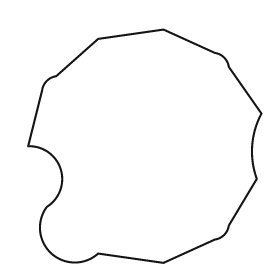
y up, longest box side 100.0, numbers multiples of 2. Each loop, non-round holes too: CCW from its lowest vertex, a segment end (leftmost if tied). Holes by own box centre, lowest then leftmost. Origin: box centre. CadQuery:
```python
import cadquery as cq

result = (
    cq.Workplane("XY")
    .moveTo(8.0, -50.0)
    .lineTo(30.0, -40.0)
    .threePointArc((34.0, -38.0), (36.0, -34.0))
    .lineTo(48.0, -14.0)
    .threePointArc((46.0, 0.0), (50.0, 14.0))
    .lineTo(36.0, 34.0)
    .threePointArc((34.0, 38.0), (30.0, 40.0))
    .lineTo(8.0, 50.0)
    .lineTo(-20.0, 46.0)
    .lineTo(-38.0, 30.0)
    .threePointArc((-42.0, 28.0), (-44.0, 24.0))
    .lineTo(-50.0, 0.0)
    .threePointArc((-36.0, -10.0), (-42.0, -26.0))
    .threePointArc((-40.0, -46.0), (-20.0, -46.0))
    .close()
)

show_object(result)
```